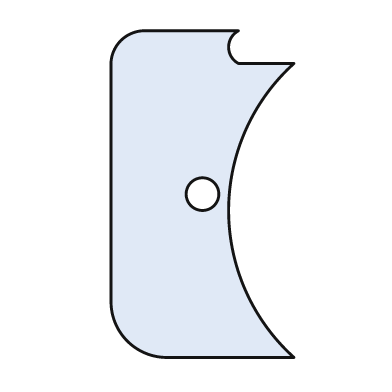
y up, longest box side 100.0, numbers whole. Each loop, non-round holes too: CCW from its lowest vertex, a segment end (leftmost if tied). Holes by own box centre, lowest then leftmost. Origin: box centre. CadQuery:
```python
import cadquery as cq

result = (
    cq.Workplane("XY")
    .moveTo(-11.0, -50.0)
    .lineTo(28.0, -50.0)
    .threePointArc((8.0, -5.0), (28.0, 40.0))
    .lineTo(11.0, 40.0)
    .threePointArc((8.0, 45.0), (11.0, 50.0))
    .lineTo(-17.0, 50.0)
    .threePointArc((-25.0, 47.0), (-28.0, 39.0))
    .lineTo(-28.0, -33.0)
    .threePointArc((-23.0, -45.0), (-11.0, -50.0))
    .close()
    .moveTo(0.0, 0.0)
    .circle(5.0)
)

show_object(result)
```